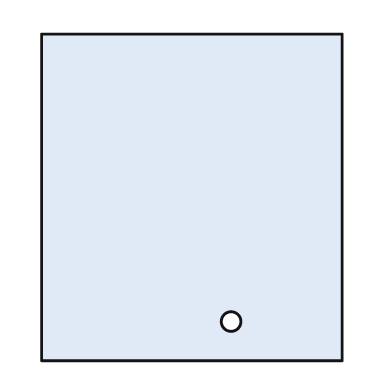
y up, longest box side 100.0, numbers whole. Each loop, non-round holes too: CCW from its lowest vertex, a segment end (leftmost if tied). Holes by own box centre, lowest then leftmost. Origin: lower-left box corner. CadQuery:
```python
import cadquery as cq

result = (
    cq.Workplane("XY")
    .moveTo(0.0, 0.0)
    .lineTo(92.0, 0.0)
    .lineTo(92.0, 100.0)
    .lineTo(0.0, 100.0)
    .close()
    .moveTo(58.0, 12.0)
    .circle(3.0)
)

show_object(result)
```